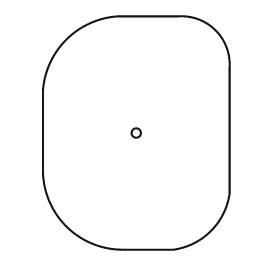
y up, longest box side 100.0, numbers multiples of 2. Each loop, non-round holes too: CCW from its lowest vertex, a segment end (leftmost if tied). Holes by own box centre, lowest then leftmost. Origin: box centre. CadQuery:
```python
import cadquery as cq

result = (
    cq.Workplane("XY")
    .moveTo(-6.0, -50.0)
    .lineTo(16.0, -50.0)
    .threePointArc((32.0, -42.0), (40.0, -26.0))
    .lineTo(40.0, 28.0)
    .threePointArc((34.0, 44.0), (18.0, 50.0))
    .lineTo(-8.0, 50.0)
    .threePointArc((-30.0, 40.0), (-40.0, 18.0))
    .lineTo(-40.0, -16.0)
    .threePointArc((-30.0, -40.0), (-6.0, -50.0))
    .close()
    .moveTo(0.0, 0.0)
    .circle(2.0)
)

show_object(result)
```